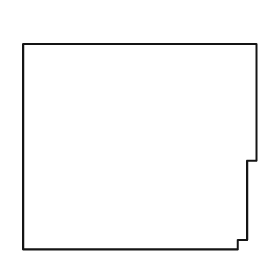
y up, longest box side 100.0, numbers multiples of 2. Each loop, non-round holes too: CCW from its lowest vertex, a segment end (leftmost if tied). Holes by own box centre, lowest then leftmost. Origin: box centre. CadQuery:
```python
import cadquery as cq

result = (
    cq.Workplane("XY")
    .moveTo(-50.0, -44.0)
    .lineTo(42.0, -44.0)
    .lineTo(42.0, -40.0)
    .lineTo(46.0, -40.0)
    .lineTo(46.0, -6.0)
    .lineTo(50.0, -6.0)
    .lineTo(50.0, 44.0)
    .lineTo(-50.0, 44.0)
    .close()
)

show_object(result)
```